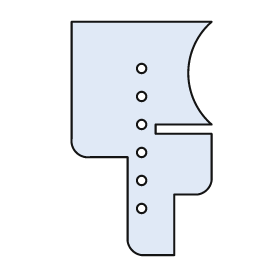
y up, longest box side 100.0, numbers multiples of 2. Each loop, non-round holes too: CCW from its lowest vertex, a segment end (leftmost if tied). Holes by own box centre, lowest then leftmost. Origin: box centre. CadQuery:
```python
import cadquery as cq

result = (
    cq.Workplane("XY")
    .moveTo(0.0, -50.0)
    .lineTo(14.0, -50.0)
    .lineTo(14.0, -24.0)
    .lineTo(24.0, -24.0)
    .threePointArc((28.0, -22.0), (30.0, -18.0))
    .lineTo(30.0, 2.0)
    .lineTo(6.0, 2.0)
    .lineTo(6.0, 6.0)
    .lineTo(30.0, 6.0)
    .threePointArc((20.0, 28.0), (30.0, 50.0))
    .lineTo(-30.0, 50.0)
    .lineTo(-30.0, 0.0)
    .threePointArc((-28.0, -6.0), (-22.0, -8.0))
    .lineTo(-6.0, -8.0)
    .lineTo(-6.0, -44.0)
    .threePointArc((-4.0, -48.0), (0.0, -50.0))
    .close()
    .moveTo(0.0, -30.0)
    .circle(2.0)
    .moveTo(0.0, -18.0)
    .circle(2.0)
    .moveTo(0.0, -6.0)
    .circle(2.0)
    .moveTo(0.0, 6.0)
    .circle(2.0)
    .moveTo(0.0, 18.0)
    .circle(2.0)
    .moveTo(0.0, 30.0)
    .circle(2.0)
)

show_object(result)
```